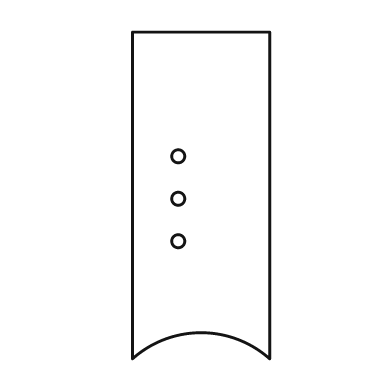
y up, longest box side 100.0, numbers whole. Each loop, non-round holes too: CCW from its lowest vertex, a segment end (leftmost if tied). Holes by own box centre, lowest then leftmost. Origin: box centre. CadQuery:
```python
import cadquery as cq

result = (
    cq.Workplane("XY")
    .moveTo(-21.0, -50.0)
    .threePointArc((0.0, -42.0), (21.0, -50.0))
    .lineTo(21.0, 50.0)
    .lineTo(-21.0, 50.0)
    .close()
    .moveTo(-7.0, -14.0)
    .circle(2.0)
    .moveTo(-7.0, -1.0)
    .circle(2.0)
    .moveTo(-7.0, 12.0)
    .circle(2.0)
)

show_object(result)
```